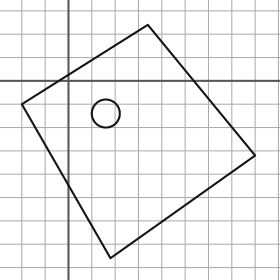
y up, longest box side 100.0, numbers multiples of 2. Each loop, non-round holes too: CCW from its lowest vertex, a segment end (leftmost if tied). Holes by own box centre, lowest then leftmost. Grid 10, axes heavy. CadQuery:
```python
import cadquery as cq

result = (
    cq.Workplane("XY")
    .moveTo(18.0, -76.0)
    .lineTo(80.0, -32.0)
    .lineTo(34.0, 24.0)
    .lineTo(-20.0, -10.0)
    .close()
    .moveTo(16.0, -14.0)
    .circle(6.0)
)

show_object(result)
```